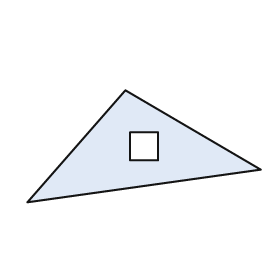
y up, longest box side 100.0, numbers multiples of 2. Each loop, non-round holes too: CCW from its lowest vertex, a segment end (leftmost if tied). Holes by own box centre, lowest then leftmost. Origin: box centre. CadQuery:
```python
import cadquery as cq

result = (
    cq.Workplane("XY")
    .moveTo(-50.0, -24.0)
    .lineTo(50.0, -10.0)
    .lineTo(-8.0, 24.0)
    .close()
    .moveTo(-6.0, -6.0)
    .lineTo(6.0, -6.0)
    .lineTo(6.0, 6.0)
    .lineTo(-6.0, 6.0)
    .close()
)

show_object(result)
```